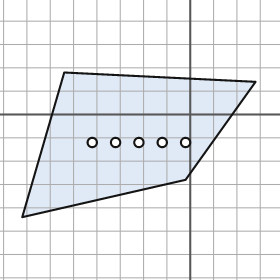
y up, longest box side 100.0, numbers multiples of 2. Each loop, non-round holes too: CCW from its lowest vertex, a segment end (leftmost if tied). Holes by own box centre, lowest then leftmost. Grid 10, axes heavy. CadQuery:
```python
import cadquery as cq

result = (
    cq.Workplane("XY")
    .moveTo(-72.0, -44.0)
    .lineTo(-2.0, -28.0)
    .lineTo(28.0, 14.0)
    .lineTo(-54.0, 18.0)
    .close()
    .moveTo(-42.0, -12.0)
    .circle(2.0)
    .moveTo(-32.0, -12.0)
    .circle(2.0)
    .moveTo(-22.0, -12.0)
    .circle(2.0)
    .moveTo(-12.0, -12.0)
    .circle(2.0)
    .moveTo(-2.0, -12.0)
    .circle(2.0)
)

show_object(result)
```